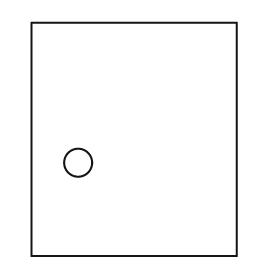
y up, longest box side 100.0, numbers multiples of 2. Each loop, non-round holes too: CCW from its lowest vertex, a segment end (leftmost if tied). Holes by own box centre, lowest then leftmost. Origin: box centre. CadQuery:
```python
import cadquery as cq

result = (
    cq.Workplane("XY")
    .moveTo(-44.0, -50.0)
    .lineTo(44.0, -50.0)
    .lineTo(44.0, 50.0)
    .lineTo(-44.0, 50.0)
    .close()
    .moveTo(-24.0, -10.0)
    .circle(6.0)
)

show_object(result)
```